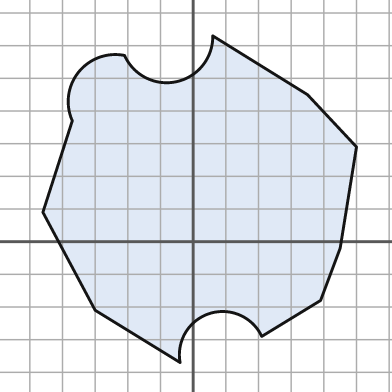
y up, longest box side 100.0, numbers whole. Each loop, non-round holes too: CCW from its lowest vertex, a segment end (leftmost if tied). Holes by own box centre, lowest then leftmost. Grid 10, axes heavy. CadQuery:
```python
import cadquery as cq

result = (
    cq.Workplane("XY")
    .moveTo(-4.0, -37.0)
    .threePointArc((5.0, -22.0), (21.0, -29.0))
    .lineTo(39.0, -18.0)
    .lineTo(45.0, -2.0)
    .lineTo(50.0, 29.0)
    .lineTo(35.0, 45.0)
    .lineTo(6.0, 63.0)
    .threePointArc((-5.0, 49.0), (-21.0, 57.0))
    .threePointArc((-35.0, 52.0), (-37.0, 37.0))
    .lineTo(-46.0, 9.0)
    .lineTo(-30.0, -21.0)
    .close()
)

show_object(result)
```